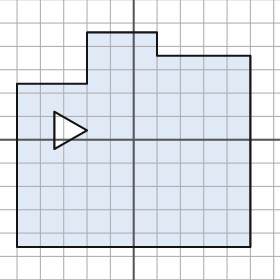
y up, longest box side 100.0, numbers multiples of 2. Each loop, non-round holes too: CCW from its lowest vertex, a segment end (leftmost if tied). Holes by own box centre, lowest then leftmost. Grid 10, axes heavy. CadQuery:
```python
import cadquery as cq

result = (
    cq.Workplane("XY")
    .moveTo(-50.0, -46.0)
    .lineTo(50.0, -46.0)
    .lineTo(50.0, 36.0)
    .lineTo(10.0, 36.0)
    .lineTo(10.0, 46.0)
    .lineTo(-20.0, 46.0)
    .lineTo(-20.0, 24.0)
    .lineTo(-50.0, 24.0)
    .close()
    .moveTo(-34.0, -4.0)
    .lineTo(-20.0, 4.0)
    .lineTo(-34.0, 12.0)
    .close()
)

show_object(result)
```